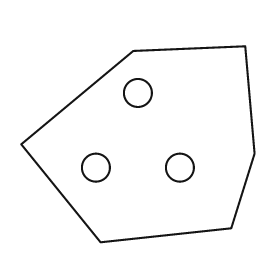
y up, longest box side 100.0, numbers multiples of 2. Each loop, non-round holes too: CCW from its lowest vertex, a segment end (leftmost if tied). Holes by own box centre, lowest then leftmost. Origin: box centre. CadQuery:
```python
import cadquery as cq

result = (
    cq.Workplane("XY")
    .moveTo(-16.0, -42.0)
    .lineTo(40.0, -36.0)
    .lineTo(50.0, -4.0)
    .lineTo(46.0, 42.0)
    .lineTo(-2.0, 40.0)
    .lineTo(-50.0, 0.0)
    .close()
    .moveTo(-18.0, -10.0)
    .circle(6.0)
    .moveTo(18.0, -10.0)
    .circle(6.0)
    .moveTo(0.0, 22.0)
    .circle(6.0)
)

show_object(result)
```